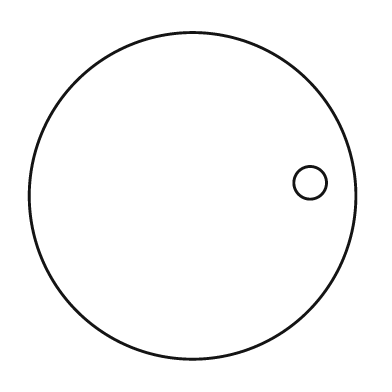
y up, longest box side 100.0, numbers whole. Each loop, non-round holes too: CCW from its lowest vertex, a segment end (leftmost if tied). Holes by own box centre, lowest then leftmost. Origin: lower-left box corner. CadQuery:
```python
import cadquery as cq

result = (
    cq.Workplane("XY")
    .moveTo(50.0, 50.0)
    .circle(50.0)
    .moveTo(86.0, 54.0)
    .circle(5.0)
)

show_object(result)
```